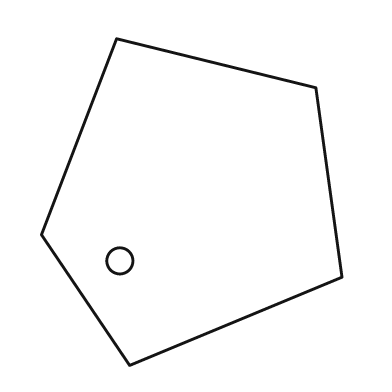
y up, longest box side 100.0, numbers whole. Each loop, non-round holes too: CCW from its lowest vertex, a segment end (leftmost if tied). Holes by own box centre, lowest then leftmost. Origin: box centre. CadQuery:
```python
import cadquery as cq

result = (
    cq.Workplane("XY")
    .moveTo(-19.0, -50.0)
    .lineTo(46.0, -23.0)
    .lineTo(38.0, 35.0)
    .lineTo(-23.0, 50.0)
    .lineTo(-46.0, -10.0)
    .close()
    .moveTo(-22.0, -18.0)
    .circle(4.0)
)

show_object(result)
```